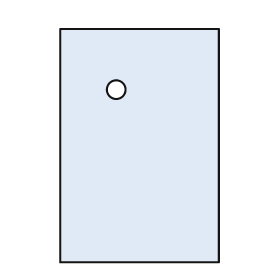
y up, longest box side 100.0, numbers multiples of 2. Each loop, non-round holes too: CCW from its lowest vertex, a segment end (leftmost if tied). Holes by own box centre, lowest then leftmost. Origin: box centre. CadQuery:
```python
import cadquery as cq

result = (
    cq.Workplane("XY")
    .moveTo(-34.0, -50.0)
    .lineTo(34.0, -50.0)
    .lineTo(34.0, 50.0)
    .lineTo(-34.0, 50.0)
    .close()
    .moveTo(-10.0, 24.0)
    .circle(4.0)
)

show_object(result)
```